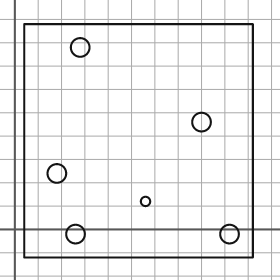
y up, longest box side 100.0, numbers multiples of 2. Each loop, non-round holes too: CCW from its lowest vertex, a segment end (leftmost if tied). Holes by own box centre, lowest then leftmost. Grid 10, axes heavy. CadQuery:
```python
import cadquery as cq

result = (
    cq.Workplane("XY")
    .moveTo(4.0, -12.0)
    .lineTo(102.0, -12.0)
    .lineTo(102.0, 88.0)
    .lineTo(4.0, 88.0)
    .close()
    .moveTo(26.0, -2.0)
    .circle(4.0)
    .moveTo(92.0, -2.0)
    .circle(4.0)
    .moveTo(56.0, 12.0)
    .circle(2.0)
    .moveTo(18.0, 24.0)
    .circle(4.0)
    .moveTo(80.0, 46.0)
    .circle(4.0)
    .moveTo(28.0, 78.0)
    .circle(4.0)
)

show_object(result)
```